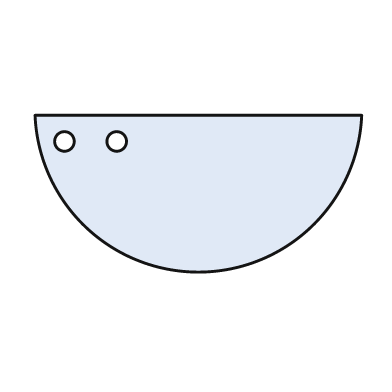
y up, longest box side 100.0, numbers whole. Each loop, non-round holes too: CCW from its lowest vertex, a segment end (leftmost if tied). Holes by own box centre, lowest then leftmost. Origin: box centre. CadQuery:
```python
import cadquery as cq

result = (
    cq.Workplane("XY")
    .moveTo(-50.0, 24.0)
    .threePointArc((0.0, -24.0), (50.0, 24.0))
    .close()
    .moveTo(-41.0, 16.0)
    .circle(3.0)
    .moveTo(-25.0, 16.0)
    .circle(3.0)
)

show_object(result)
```